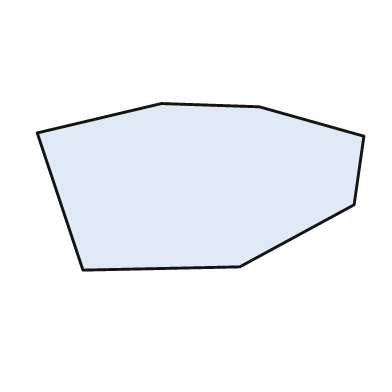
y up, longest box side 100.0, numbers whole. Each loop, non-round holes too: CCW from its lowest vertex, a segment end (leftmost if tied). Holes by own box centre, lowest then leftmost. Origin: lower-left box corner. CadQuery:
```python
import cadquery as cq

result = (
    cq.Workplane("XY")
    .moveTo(14.0, 0.0)
    .lineTo(62.0, 1.0)
    .lineTo(97.0, 20.0)
    .lineTo(100.0, 41.0)
    .lineTo(68.0, 50.0)
    .lineTo(38.0, 51.0)
    .lineTo(0.0, 42.0)
    .close()
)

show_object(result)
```